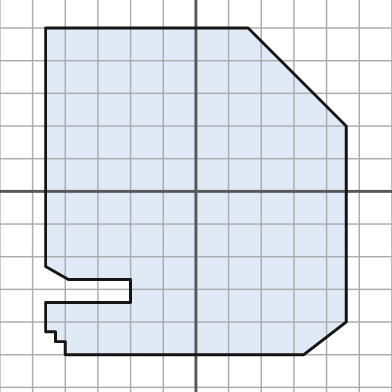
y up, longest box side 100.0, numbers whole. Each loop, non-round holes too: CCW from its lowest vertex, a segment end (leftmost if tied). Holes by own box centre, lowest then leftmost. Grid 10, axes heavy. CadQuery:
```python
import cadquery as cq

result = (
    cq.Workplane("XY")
    .moveTo(-40.0, -50.0)
    .lineTo(33.0, -50.0)
    .lineTo(46.0, -40.0)
    .lineTo(46.0, 20.0)
    .lineTo(16.0, 50.0)
    .lineTo(-46.0, 50.0)
    .lineTo(-46.0, -23.0)
    .lineTo(-39.0, -27.0)
    .lineTo(-20.0, -27.0)
    .lineTo(-20.0, -34.0)
    .lineTo(-46.0, -34.0)
    .lineTo(-46.0, -43.0)
    .lineTo(-43.0, -43.0)
    .lineTo(-43.0, -46.0)
    .lineTo(-40.0, -46.0)
    .close()
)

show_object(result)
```